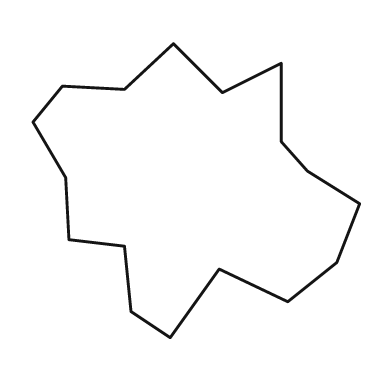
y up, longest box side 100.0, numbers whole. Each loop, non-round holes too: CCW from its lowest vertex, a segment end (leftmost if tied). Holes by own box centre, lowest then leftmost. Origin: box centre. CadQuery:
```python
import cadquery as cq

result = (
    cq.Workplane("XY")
    .moveTo(-8.0, -45.0)
    .lineTo(7.0, -24.0)
    .lineTo(28.0, -34.0)
    .lineTo(43.0, -22.0)
    .lineTo(50.0, -4.0)
    .lineTo(34.0, 6.0)
    .lineTo(26.0, 15.0)
    .lineTo(26.0, 39.0)
    .lineTo(8.0, 30.0)
    .lineTo(-7.0, 45.0)
    .lineTo(-22.0, 31.0)
    .lineTo(-41.0, 32.0)
    .lineTo(-50.0, 21.0)
    .lineTo(-40.0, 4.0)
    .lineTo(-39.0, -15.0)
    .lineTo(-22.0, -17.0)
    .lineTo(-20.0, -37.0)
    .close()
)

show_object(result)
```